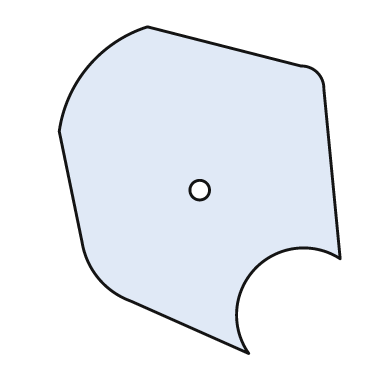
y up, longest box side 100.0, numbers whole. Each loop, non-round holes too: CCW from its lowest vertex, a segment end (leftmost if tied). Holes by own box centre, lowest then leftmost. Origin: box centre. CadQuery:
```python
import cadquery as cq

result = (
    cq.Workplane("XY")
    .moveTo(15.0, -50.0)
    .threePointArc((17.0, -24.0), (43.0, -21.0))
    .lineTo(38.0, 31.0)
    .threePointArc((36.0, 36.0), (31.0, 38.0))
    .lineTo(-16.0, 50.0)
    .threePointArc((-34.0, 38.0), (-43.0, 18.0))
    .lineTo(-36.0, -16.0)
    .threePointArc((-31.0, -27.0), (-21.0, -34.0))
    .close()
    .moveTo(0.0, 0.0)
    .circle(3.0)
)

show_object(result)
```